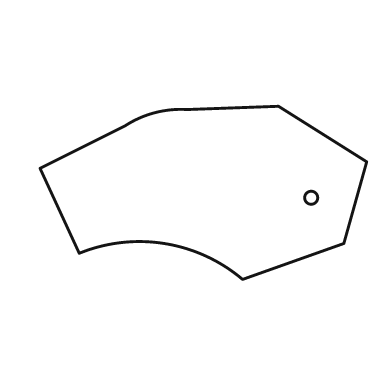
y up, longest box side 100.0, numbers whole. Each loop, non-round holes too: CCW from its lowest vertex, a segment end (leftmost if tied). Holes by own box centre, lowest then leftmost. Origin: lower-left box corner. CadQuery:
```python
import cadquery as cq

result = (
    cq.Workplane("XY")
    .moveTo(62.0, 0.0)
    .lineTo(93.0, 11.0)
    .lineTo(100.0, 36.0)
    .lineTo(73.0, 53.0)
    .lineTo(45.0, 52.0)
    .threePointArc((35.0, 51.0), (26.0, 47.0))
    .lineTo(0.0, 34.0)
    .lineTo(12.0, 8.0)
    .threePointArc((38.0, 11.0), (62.0, 0.0))
    .close()
    .moveTo(83.0, 25.0)
    .circle(2.0)
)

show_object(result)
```